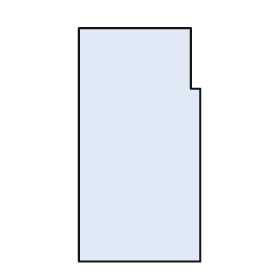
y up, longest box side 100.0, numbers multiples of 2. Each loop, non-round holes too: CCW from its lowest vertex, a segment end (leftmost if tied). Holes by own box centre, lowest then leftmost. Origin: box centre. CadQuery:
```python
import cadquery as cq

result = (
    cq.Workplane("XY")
    .moveTo(-26.0, -50.0)
    .lineTo(26.0, -50.0)
    .lineTo(26.0, 24.0)
    .lineTo(22.0, 24.0)
    .lineTo(22.0, 50.0)
    .lineTo(-26.0, 50.0)
    .close()
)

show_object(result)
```